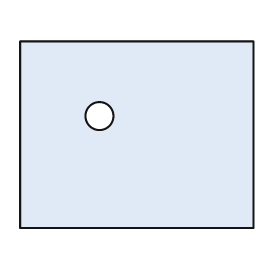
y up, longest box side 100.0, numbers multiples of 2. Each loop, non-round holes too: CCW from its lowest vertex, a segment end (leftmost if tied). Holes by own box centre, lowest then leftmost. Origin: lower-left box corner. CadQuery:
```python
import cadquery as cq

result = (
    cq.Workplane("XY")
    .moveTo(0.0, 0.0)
    .lineTo(100.0, 0.0)
    .lineTo(100.0, 80.0)
    .lineTo(0.0, 80.0)
    .close()
    .moveTo(34.0, 48.0)
    .circle(6.0)
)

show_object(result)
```